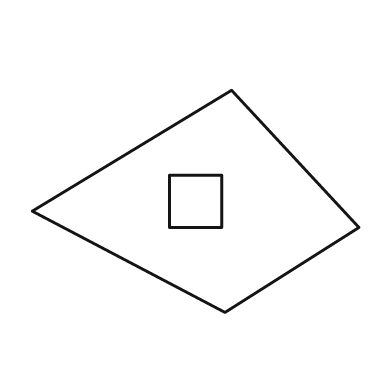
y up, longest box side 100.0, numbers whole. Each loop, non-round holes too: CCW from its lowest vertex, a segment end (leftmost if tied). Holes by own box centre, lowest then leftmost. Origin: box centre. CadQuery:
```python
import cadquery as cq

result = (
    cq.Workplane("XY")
    .moveTo(9.0, -34.0)
    .lineTo(50.0, -8.0)
    .lineTo(11.0, 34.0)
    .lineTo(-50.0, -3.0)
    .close()
    .moveTo(-8.0, -8.0)
    .lineTo(8.0, -8.0)
    .lineTo(8.0, 8.0)
    .lineTo(-8.0, 8.0)
    .close()
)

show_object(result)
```